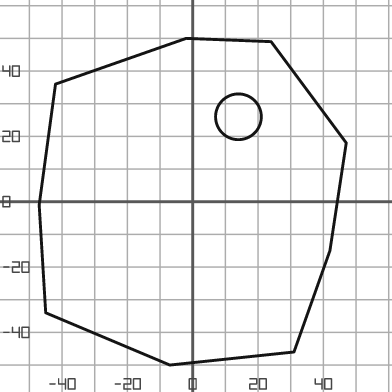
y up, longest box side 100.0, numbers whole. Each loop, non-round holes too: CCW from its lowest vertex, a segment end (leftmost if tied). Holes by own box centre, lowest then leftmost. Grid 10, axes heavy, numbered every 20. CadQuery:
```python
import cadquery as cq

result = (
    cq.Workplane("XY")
    .moveTo(-7.0, -50.0)
    .lineTo(31.0, -46.0)
    .lineTo(42.0, -15.0)
    .lineTo(47.0, 18.0)
    .lineTo(24.0, 49.0)
    .lineTo(-2.0, 50.0)
    .lineTo(-42.0, 36.0)
    .lineTo(-47.0, -1.0)
    .lineTo(-45.0, -34.0)
    .close()
    .moveTo(14.0, 26.0)
    .circle(7.0)
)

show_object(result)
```